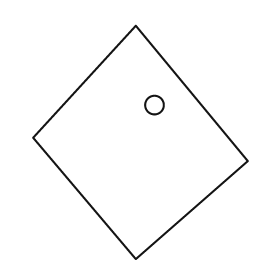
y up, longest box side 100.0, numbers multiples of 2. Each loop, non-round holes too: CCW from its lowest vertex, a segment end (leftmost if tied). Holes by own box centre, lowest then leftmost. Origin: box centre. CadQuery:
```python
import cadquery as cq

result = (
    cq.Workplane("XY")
    .moveTo(-2.0, -50.0)
    .lineTo(46.0, -8.0)
    .lineTo(-2.0, 50.0)
    .lineTo(-46.0, 2.0)
    .close()
    .moveTo(6.0, 16.0)
    .circle(4.0)
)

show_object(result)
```